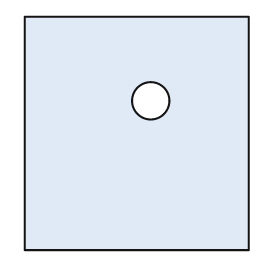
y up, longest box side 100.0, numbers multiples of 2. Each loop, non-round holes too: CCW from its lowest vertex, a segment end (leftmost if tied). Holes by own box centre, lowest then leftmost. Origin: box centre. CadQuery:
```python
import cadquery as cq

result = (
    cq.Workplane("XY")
    .moveTo(-48.0, -50.0)
    .lineTo(48.0, -50.0)
    .lineTo(48.0, 50.0)
    .lineTo(-48.0, 50.0)
    .close()
    .moveTo(6.0, 14.0)
    .circle(8.0)
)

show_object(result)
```